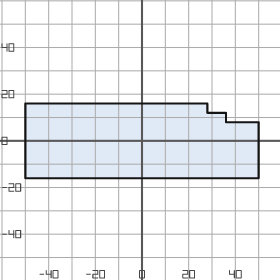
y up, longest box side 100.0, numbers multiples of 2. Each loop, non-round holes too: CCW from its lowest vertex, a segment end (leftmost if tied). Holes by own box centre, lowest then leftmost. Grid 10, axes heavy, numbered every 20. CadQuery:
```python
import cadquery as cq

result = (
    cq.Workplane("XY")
    .moveTo(-50.0, -16.0)
    .lineTo(50.0, -16.0)
    .lineTo(50.0, 8.0)
    .lineTo(36.0, 8.0)
    .lineTo(36.0, 12.0)
    .lineTo(28.0, 12.0)
    .lineTo(28.0, 16.0)
    .lineTo(-50.0, 16.0)
    .close()
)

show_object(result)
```